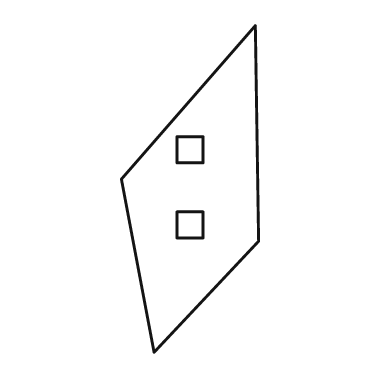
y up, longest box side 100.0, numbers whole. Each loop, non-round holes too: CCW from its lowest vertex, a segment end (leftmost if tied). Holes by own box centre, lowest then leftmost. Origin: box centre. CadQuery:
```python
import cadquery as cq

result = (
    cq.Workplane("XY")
    .moveTo(-11.0, -50.0)
    .lineTo(21.0, -16.0)
    .lineTo(20.0, 50.0)
    .lineTo(-21.0, 3.0)
    .close()
    .moveTo(-4.0, -15.0)
    .lineTo(4.0, -15.0)
    .lineTo(4.0, -7.0)
    .lineTo(-4.0, -7.0)
    .close()
    .moveTo(-4.0, 8.0)
    .lineTo(4.0, 8.0)
    .lineTo(4.0, 16.0)
    .lineTo(-4.0, 16.0)
    .close()
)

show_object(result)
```